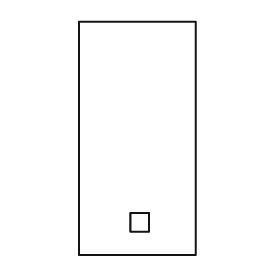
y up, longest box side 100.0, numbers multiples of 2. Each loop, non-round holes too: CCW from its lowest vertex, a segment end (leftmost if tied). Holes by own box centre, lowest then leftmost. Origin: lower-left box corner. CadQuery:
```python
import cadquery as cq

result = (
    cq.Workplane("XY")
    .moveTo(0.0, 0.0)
    .lineTo(50.0, 0.0)
    .lineTo(50.0, 100.0)
    .lineTo(0.0, 100.0)
    .close()
    .moveTo(22.0, 10.0)
    .lineTo(30.0, 10.0)
    .lineTo(30.0, 18.0)
    .lineTo(22.0, 18.0)
    .close()
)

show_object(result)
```